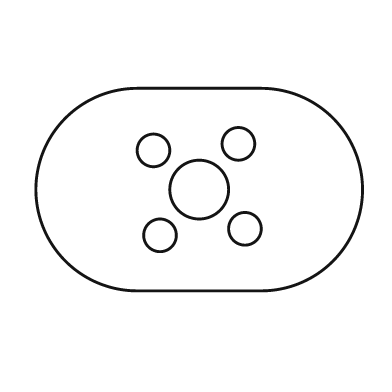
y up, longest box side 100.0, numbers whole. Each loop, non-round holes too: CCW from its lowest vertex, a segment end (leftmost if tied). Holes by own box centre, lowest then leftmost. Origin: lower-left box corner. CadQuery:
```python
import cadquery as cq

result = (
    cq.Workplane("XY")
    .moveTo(31.0, 0.0)
    .lineTo(69.0, 0.0)
    .threePointArc((100.0, 31.0), (69.0, 62.0))
    .lineTo(31.0, 62.0)
    .threePointArc((0.0, 31.0), (31.0, 0.0))
    .close()
    .moveTo(38.0, 17.0)
    .circle(5.0)
    .moveTo(64.0, 19.0)
    .circle(5.0)
    .moveTo(50.0, 31.0)
    .circle(9.0)
    .moveTo(36.0, 43.0)
    .circle(5.0)
    .moveTo(62.0, 45.0)
    .circle(5.0)
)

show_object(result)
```